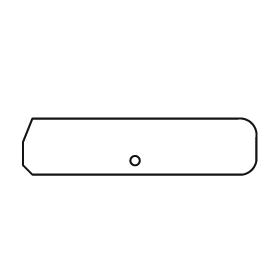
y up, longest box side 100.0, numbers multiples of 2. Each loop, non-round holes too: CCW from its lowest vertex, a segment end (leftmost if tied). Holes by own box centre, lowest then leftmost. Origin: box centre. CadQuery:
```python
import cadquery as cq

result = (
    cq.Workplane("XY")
    .moveTo(-46.0, -12.0)
    .lineTo(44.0, -12.0)
    .threePointArc((48.0, -10.0), (50.0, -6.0))
    .lineTo(50.0, 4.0)
    .threePointArc((48.0, 10.0), (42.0, 12.0))
    .lineTo(-46.0, 12.0)
    .lineTo(-50.0, 2.0)
    .lineTo(-50.0, -8.0)
    .close()
    .moveTo(-2.0, -6.0)
    .circle(2.0)
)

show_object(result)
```